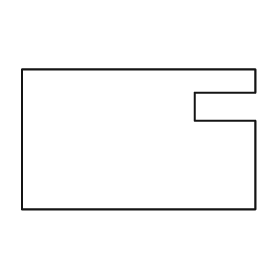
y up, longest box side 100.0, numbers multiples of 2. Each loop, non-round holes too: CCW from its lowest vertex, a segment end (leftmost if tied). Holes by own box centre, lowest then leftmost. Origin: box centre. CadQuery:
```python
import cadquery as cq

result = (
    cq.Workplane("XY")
    .moveTo(-50.0, -30.0)
    .lineTo(50.0, -30.0)
    .lineTo(50.0, 8.0)
    .lineTo(24.0, 8.0)
    .lineTo(24.0, 20.0)
    .lineTo(50.0, 20.0)
    .lineTo(50.0, 30.0)
    .lineTo(-50.0, 30.0)
    .close()
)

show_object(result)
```